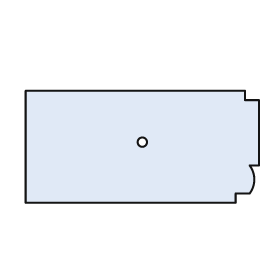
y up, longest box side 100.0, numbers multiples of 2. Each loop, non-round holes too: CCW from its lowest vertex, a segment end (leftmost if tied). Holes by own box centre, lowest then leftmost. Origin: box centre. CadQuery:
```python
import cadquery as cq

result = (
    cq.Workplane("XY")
    .moveTo(-50.0, -24.0)
    .lineTo(40.0, -24.0)
    .lineTo(40.0, -20.0)
    .lineTo(46.0, -20.0)
    .threePointArc((48.0, -14.0), (46.0, -8.0))
    .lineTo(50.0, -8.0)
    .lineTo(50.0, 20.0)
    .lineTo(44.0, 20.0)
    .lineTo(44.0, 24.0)
    .lineTo(-50.0, 24.0)
    .close()
    .moveTo(0.0, 2.0)
    .circle(2.0)
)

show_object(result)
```